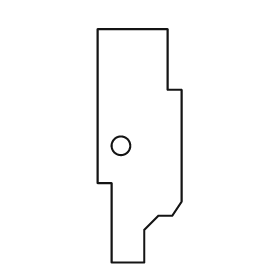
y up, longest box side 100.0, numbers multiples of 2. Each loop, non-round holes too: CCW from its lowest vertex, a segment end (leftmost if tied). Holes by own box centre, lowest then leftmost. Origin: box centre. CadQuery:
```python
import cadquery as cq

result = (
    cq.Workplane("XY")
    .moveTo(-12.0, -50.0)
    .lineTo(2.0, -50.0)
    .lineTo(2.0, -36.0)
    .lineTo(8.0, -30.0)
    .lineTo(14.0, -30.0)
    .lineTo(18.0, -24.0)
    .lineTo(18.0, 24.0)
    .lineTo(12.0, 24.0)
    .lineTo(12.0, 50.0)
    .lineTo(-18.0, 50.0)
    .lineTo(-18.0, -16.0)
    .lineTo(-12.0, -16.0)
    .close()
    .moveTo(-8.0, 0.0)
    .circle(4.0)
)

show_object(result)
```